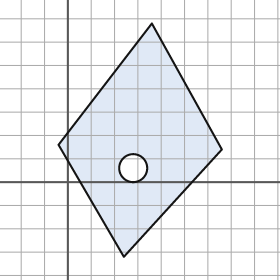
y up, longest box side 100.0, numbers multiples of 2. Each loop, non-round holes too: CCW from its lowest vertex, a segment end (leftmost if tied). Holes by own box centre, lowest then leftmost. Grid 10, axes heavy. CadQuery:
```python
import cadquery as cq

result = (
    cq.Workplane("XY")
    .moveTo(24.0, -32.0)
    .lineTo(66.0, 14.0)
    .lineTo(36.0, 68.0)
    .lineTo(-4.0, 16.0)
    .close()
    .moveTo(28.0, 6.0)
    .circle(6.0)
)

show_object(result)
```